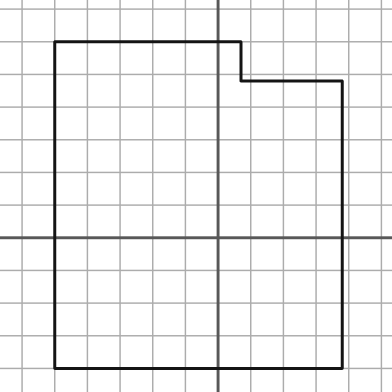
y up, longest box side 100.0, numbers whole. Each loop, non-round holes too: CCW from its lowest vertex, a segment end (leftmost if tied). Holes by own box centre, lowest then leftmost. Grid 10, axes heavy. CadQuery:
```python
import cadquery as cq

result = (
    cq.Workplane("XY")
    .moveTo(-50.0, -40.0)
    .lineTo(38.0, -40.0)
    .lineTo(38.0, 48.0)
    .lineTo(7.0, 48.0)
    .lineTo(7.0, 60.0)
    .lineTo(-50.0, 60.0)
    .close()
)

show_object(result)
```